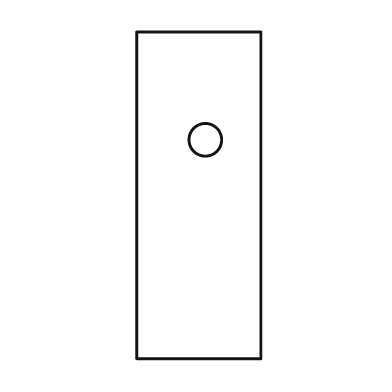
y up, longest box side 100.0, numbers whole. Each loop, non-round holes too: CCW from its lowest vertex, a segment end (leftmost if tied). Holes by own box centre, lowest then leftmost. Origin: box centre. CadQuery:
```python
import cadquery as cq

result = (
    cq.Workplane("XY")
    .moveTo(-19.0, -50.0)
    .lineTo(19.0, -50.0)
    .lineTo(19.0, 50.0)
    .lineTo(-19.0, 50.0)
    .close()
    .moveTo(2.0, 17.0)
    .circle(5.0)
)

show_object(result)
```